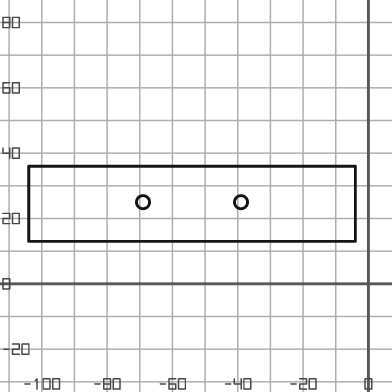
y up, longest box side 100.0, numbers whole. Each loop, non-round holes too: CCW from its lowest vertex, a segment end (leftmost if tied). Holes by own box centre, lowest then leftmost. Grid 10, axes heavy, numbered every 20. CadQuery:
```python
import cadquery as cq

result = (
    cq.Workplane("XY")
    .moveTo(-104.0, 13.0)
    .lineTo(-4.0, 13.0)
    .lineTo(-4.0, 36.0)
    .lineTo(-104.0, 36.0)
    .close()
    .moveTo(-69.0, 25.0)
    .circle(2.0)
    .moveTo(-39.0, 25.0)
    .circle(2.0)
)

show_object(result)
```